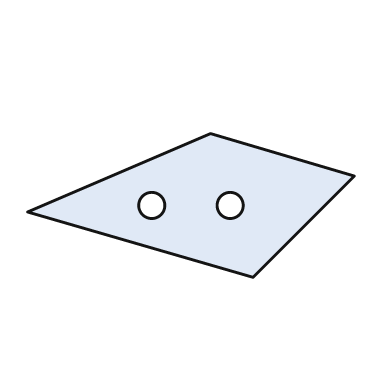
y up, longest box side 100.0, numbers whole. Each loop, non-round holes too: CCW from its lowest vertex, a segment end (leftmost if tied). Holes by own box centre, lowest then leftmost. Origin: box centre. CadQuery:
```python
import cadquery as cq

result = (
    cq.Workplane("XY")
    .moveTo(19.0, -22.0)
    .lineTo(50.0, 9.0)
    .lineTo(6.0, 22.0)
    .lineTo(-50.0, -2.0)
    .close()
    .moveTo(-12.0, 0.0)
    .circle(4.0)
    .moveTo(12.0, 0.0)
    .circle(4.0)
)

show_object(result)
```